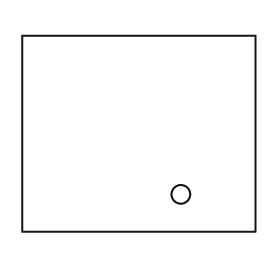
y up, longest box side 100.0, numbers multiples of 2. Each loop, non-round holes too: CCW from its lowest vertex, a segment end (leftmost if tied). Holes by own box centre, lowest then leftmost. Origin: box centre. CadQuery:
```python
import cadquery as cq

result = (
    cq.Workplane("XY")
    .moveTo(-50.0, -42.0)
    .lineTo(50.0, -42.0)
    .lineTo(50.0, 42.0)
    .lineTo(-50.0, 42.0)
    .close()
    .moveTo(18.0, -26.0)
    .circle(4.0)
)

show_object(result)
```